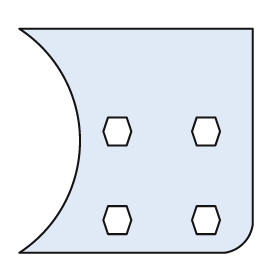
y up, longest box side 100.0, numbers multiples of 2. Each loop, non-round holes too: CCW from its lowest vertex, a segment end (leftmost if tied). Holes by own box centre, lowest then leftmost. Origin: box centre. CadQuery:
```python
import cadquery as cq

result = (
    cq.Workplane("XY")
    .moveTo(-50.0, -48.0)
    .lineTo(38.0, -48.0)
    .threePointArc((46.0, -44.0), (50.0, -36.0))
    .lineTo(50.0, 48.0)
    .lineTo(-50.0, 48.0)
    .threePointArc((-24.0, 0.0), (-50.0, -48.0))
    .close()
    .moveTo(-12.0, -40.0)
    .lineTo(-4.0, -40.0)
    .lineTo(-2.0, -34.0)
    .lineTo(-4.0, -28.0)
    .lineTo(-12.0, -28.0)
    .lineTo(-14.0, -34.0)
    .close()
    .moveTo(26.0, -40.0)
    .lineTo(34.0, -40.0)
    .lineTo(36.0, -34.0)
    .lineTo(34.0, -28.0)
    .lineTo(26.0, -28.0)
    .lineTo(24.0, -34.0)
    .close()
    .moveTo(-12.0, -2.0)
    .lineTo(-4.0, -2.0)
    .lineTo(-2.0, 4.0)
    .lineTo(-4.0, 10.0)
    .lineTo(-12.0, 10.0)
    .lineTo(-14.0, 4.0)
    .close()
    .moveTo(26.0, -2.0)
    .lineTo(34.0, -2.0)
    .lineTo(36.0, 4.0)
    .lineTo(34.0, 10.0)
    .lineTo(26.0, 10.0)
    .lineTo(24.0, 4.0)
    .close()
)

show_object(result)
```